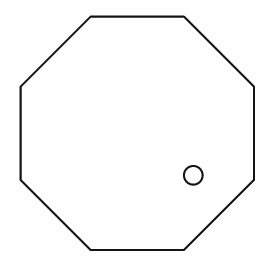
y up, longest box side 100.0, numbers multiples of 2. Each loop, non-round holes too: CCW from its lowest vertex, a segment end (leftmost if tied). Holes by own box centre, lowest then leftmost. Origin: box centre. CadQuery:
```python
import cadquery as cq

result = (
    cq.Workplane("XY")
    .moveTo(-20.0, -50.0)
    .lineTo(20.0, -50.0)
    .lineTo(50.0, -20.0)
    .lineTo(50.0, 20.0)
    .lineTo(20.0, 50.0)
    .lineTo(-20.0, 50.0)
    .lineTo(-50.0, 20.0)
    .lineTo(-50.0, -20.0)
    .close()
    .moveTo(24.0, -18.0)
    .circle(4.0)
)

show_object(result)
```